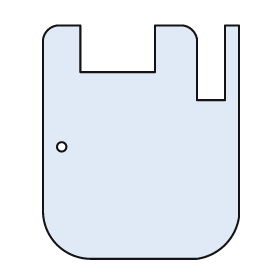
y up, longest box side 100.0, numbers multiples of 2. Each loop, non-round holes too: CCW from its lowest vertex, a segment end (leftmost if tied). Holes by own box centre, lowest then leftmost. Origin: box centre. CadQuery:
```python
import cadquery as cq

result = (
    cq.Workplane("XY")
    .moveTo(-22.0, -50.0)
    .lineTo(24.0, -50.0)
    .threePointArc((36.0, -44.0), (42.0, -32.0))
    .lineTo(42.0, 50.0)
    .lineTo(36.0, 50.0)
    .lineTo(36.0, 18.0)
    .lineTo(24.0, 18.0)
    .lineTo(24.0, 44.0)
    .threePointArc((22.0, 48.0), (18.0, 50.0))
    .lineTo(6.0, 50.0)
    .lineTo(6.0, 30.0)
    .lineTo(-26.0, 30.0)
    .lineTo(-26.0, 50.0)
    .lineTo(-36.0, 50.0)
    .threePointArc((-40.0, 48.0), (-42.0, 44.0))
    .lineTo(-42.0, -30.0)
    .threePointArc((-36.0, -44.0), (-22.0, -50.0))
    .close()
    .moveTo(-34.0, -2.0)
    .circle(2.0)
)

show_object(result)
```